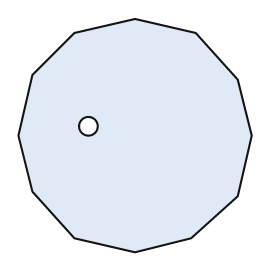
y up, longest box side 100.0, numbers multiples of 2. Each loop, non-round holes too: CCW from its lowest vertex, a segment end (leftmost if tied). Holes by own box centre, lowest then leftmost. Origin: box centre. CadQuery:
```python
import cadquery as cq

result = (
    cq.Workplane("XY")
    .moveTo(0.0, -50.0)
    .lineTo(24.0, -44.0)
    .lineTo(44.0, -26.0)
    .lineTo(50.0, 0.0)
    .lineTo(44.0, 24.0)
    .lineTo(26.0, 44.0)
    .lineTo(0.0, 50.0)
    .lineTo(-26.0, 44.0)
    .lineTo(-44.0, 26.0)
    .lineTo(-50.0, 0.0)
    .lineTo(-44.0, -24.0)
    .lineTo(-26.0, -44.0)
    .close()
    .moveTo(-20.0, 4.0)
    .circle(4.0)
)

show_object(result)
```